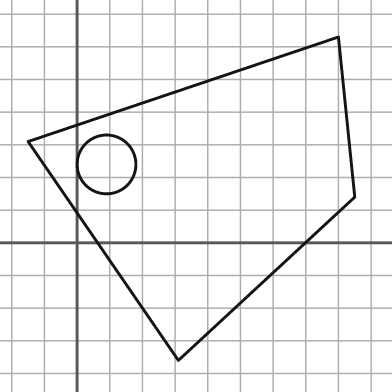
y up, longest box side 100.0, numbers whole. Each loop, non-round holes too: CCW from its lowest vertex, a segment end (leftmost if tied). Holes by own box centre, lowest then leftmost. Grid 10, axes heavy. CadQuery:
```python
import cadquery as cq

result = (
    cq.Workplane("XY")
    .moveTo(31.0, -36.0)
    .lineTo(85.0, 14.0)
    .lineTo(80.0, 63.0)
    .lineTo(-15.0, 31.0)
    .close()
    .moveTo(9.0, 24.0)
    .circle(9.0)
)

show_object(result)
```